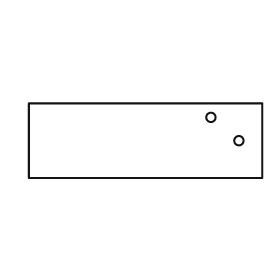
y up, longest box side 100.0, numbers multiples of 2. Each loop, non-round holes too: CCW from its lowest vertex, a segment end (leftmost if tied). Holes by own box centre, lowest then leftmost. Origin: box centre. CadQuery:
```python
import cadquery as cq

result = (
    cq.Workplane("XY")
    .moveTo(-50.0, -16.0)
    .lineTo(50.0, -16.0)
    .lineTo(50.0, 16.0)
    .lineTo(-50.0, 16.0)
    .close()
    .moveTo(40.0, 0.0)
    .circle(2.0)
    .moveTo(28.0, 10.0)
    .circle(2.0)
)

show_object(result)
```